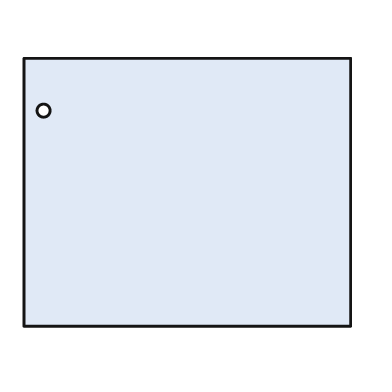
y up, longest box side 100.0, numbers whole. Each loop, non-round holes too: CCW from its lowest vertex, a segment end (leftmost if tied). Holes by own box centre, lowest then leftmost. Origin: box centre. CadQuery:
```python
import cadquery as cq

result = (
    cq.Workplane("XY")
    .moveTo(-50.0, -41.0)
    .lineTo(50.0, -41.0)
    .lineTo(50.0, 41.0)
    .lineTo(-50.0, 41.0)
    .close()
    .moveTo(-44.0, 25.0)
    .circle(2.0)
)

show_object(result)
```